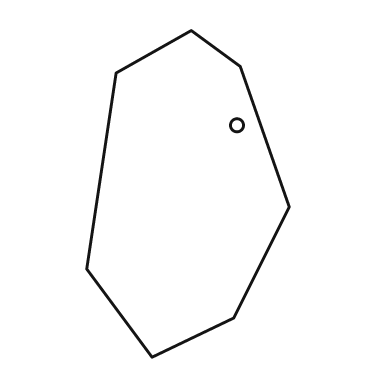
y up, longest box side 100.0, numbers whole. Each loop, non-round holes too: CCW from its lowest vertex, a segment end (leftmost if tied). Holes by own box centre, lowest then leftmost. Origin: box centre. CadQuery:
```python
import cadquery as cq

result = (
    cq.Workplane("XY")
    .moveTo(-11.0, -50.0)
    .lineTo(14.0, -38.0)
    .lineTo(31.0, -4.0)
    .lineTo(16.0, 39.0)
    .lineTo(1.0, 50.0)
    .lineTo(-22.0, 37.0)
    .lineTo(-31.0, -23.0)
    .close()
    .moveTo(15.0, 21.0)
    .circle(2.0)
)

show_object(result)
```